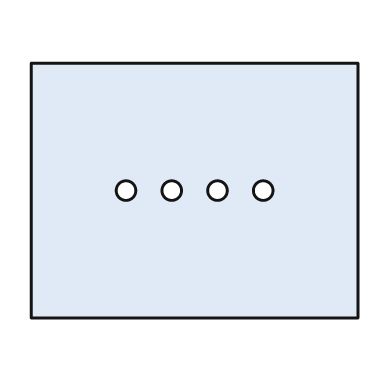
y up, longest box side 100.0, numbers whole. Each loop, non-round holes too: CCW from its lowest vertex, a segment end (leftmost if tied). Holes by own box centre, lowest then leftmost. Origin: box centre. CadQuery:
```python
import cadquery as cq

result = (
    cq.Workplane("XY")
    .moveTo(-50.0, -39.0)
    .lineTo(50.0, -39.0)
    .lineTo(50.0, 39.0)
    .lineTo(-50.0, 39.0)
    .close()
    .moveTo(-21.0, 0.0)
    .circle(3.0)
    .moveTo(-7.0, 0.0)
    .circle(3.0)
    .moveTo(7.0, 0.0)
    .circle(3.0)
    .moveTo(21.0, 0.0)
    .circle(3.0)
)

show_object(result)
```